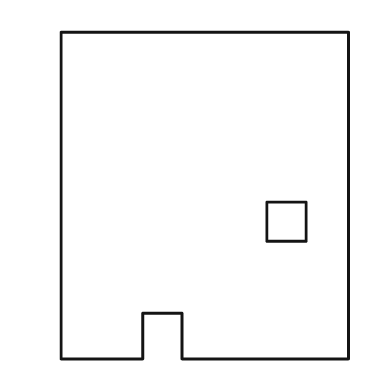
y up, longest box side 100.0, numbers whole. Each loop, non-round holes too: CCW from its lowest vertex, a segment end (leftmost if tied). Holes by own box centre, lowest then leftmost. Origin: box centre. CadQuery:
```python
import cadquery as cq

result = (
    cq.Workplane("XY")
    .moveTo(-44.0, -50.0)
    .lineTo(-19.0, -50.0)
    .lineTo(-19.0, -36.0)
    .lineTo(-7.0, -36.0)
    .lineTo(-7.0, -50.0)
    .lineTo(44.0, -50.0)
    .lineTo(44.0, 50.0)
    .lineTo(-44.0, 50.0)
    .close()
    .moveTo(19.0, -14.0)
    .lineTo(31.0, -14.0)
    .lineTo(31.0, -2.0)
    .lineTo(19.0, -2.0)
    .close()
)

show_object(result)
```